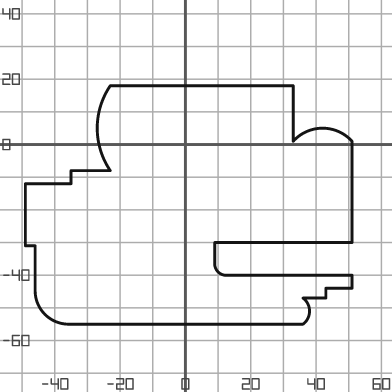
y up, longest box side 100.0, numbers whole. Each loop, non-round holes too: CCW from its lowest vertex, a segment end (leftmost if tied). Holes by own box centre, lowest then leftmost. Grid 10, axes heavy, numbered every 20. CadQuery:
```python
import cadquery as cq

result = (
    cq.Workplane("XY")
    .moveTo(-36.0, -55.0)
    .lineTo(36.0, -55.0)
    .threePointArc((38.0, -51.0), (36.0, -47.0))
    .lineTo(43.0, -47.0)
    .lineTo(43.0, -44.0)
    .lineTo(51.0, -44.0)
    .lineTo(51.0, -40.0)
    .lineTo(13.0, -40.0)
    .threePointArc((10.0, -39.0), (9.0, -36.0))
    .lineTo(9.0, -30.0)
    .lineTo(51.0, -30.0)
    .lineTo(51.0, 1.0)
    .threePointArc((42.0, 5.0), (33.0, 1.0))
    .lineTo(33.0, 18.0)
    .lineTo(-23.0, 18.0)
    .threePointArc((-27.0, 5.0), (-23.0, -8.0))
    .lineTo(-35.0, -8.0)
    .lineTo(-35.0, -12.0)
    .lineTo(-49.0, -12.0)
    .lineTo(-49.0, -31.0)
    .lineTo(-46.0, -31.0)
    .lineTo(-46.0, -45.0)
    .threePointArc((-43.0, -52.0), (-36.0, -55.0))
    .close()
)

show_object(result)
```